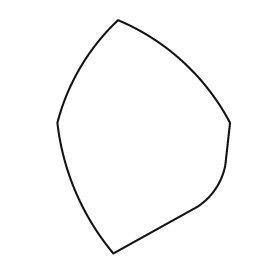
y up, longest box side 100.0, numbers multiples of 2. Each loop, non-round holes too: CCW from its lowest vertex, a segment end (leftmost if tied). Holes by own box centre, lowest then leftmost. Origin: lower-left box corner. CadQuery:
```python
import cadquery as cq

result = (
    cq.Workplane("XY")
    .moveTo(24.0, 0.0)
    .lineTo(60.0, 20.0)
    .threePointArc((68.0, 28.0), (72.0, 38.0))
    .lineTo(74.0, 56.0)
    .threePointArc((54.0, 82.0), (26.0, 100.0))
    .threePointArc((10.0, 80.0), (0.0, 56.0))
    .threePointArc((8.0, 26.0), (24.0, 0.0))
    .close()
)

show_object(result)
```